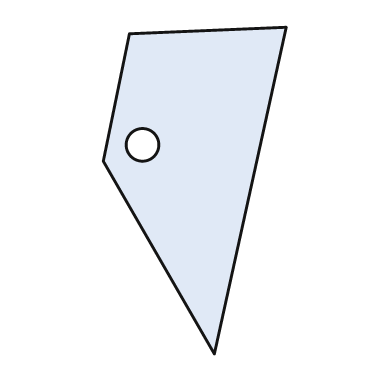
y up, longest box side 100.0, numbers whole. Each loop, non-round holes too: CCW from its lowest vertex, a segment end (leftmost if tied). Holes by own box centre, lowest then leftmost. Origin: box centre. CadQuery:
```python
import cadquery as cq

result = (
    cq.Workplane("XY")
    .moveTo(6.0, -50.0)
    .lineTo(28.0, 50.0)
    .lineTo(-20.0, 48.0)
    .lineTo(-28.0, 9.0)
    .close()
    .moveTo(-16.0, 14.0)
    .circle(5.0)
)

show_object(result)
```